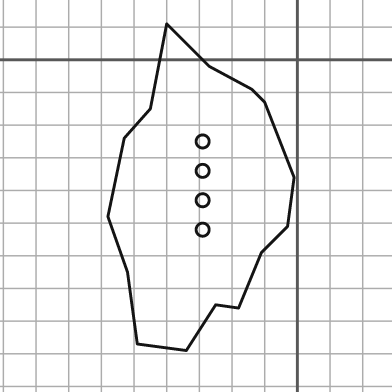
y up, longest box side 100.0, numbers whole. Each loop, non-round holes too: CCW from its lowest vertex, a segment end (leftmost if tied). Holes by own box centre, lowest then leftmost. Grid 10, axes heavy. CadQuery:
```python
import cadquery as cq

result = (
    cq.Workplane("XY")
    .moveTo(-34.0, -89.0)
    .lineTo(-25.0, -75.0)
    .lineTo(-18.0, -76.0)
    .lineTo(-11.0, -59.0)
    .lineTo(-3.0, -51.0)
    .lineTo(-1.0, -36.0)
    .lineTo(-10.0, -13.0)
    .lineTo(-14.0, -9.0)
    .lineTo(-27.0, -2.0)
    .lineTo(-40.0, 11.0)
    .lineTo(-45.0, -15.0)
    .lineTo(-53.0, -24.0)
    .lineTo(-58.0, -48.0)
    .lineTo(-52.0, -65.0)
    .lineTo(-49.0, -87.0)
    .close()
    .moveTo(-29.0, -52.0)
    .circle(2.0)
    .moveTo(-29.0, -43.0)
    .circle(2.0)
    .moveTo(-29.0, -34.0)
    .circle(2.0)
    .moveTo(-29.0, -25.0)
    .circle(2.0)
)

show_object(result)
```